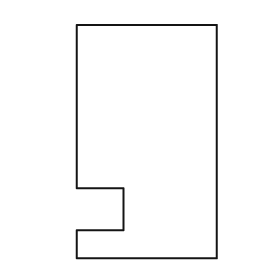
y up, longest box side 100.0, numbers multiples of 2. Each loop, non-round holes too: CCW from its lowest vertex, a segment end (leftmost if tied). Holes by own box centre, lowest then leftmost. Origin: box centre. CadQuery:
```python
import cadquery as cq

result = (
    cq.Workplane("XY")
    .moveTo(-30.0, -50.0)
    .lineTo(30.0, -50.0)
    .lineTo(30.0, 50.0)
    .lineTo(-30.0, 50.0)
    .lineTo(-30.0, -20.0)
    .lineTo(-10.0, -20.0)
    .lineTo(-10.0, -38.0)
    .lineTo(-30.0, -38.0)
    .close()
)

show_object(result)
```